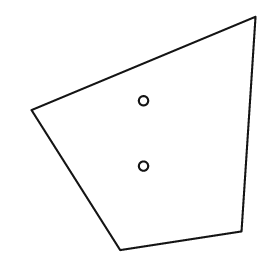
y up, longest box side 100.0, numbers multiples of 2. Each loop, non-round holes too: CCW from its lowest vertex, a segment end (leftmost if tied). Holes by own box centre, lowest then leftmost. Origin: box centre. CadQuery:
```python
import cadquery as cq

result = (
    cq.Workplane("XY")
    .moveTo(-10.0, -50.0)
    .lineTo(42.0, -42.0)
    .lineTo(48.0, 50.0)
    .lineTo(-48.0, 10.0)
    .close()
    .moveTo(0.0, -14.0)
    .circle(2.0)
    .moveTo(0.0, 14.0)
    .circle(2.0)
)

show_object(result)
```